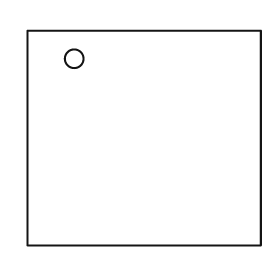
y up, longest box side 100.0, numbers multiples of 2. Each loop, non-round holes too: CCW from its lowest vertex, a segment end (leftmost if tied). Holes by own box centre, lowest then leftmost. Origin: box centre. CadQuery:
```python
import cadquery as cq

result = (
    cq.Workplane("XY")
    .moveTo(-50.0, -46.0)
    .lineTo(50.0, -46.0)
    .lineTo(50.0, 46.0)
    .lineTo(-50.0, 46.0)
    .close()
    .moveTo(-30.0, 34.0)
    .circle(4.0)
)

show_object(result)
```